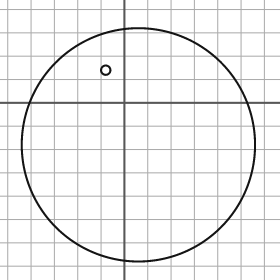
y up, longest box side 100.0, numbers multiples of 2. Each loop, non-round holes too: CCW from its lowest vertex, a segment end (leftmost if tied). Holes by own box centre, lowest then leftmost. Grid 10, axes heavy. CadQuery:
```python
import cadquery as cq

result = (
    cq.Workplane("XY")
    .moveTo(6.0, -18.0)
    .circle(50.0)
    .moveTo(-8.0, 14.0)
    .circle(2.0)
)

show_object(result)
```